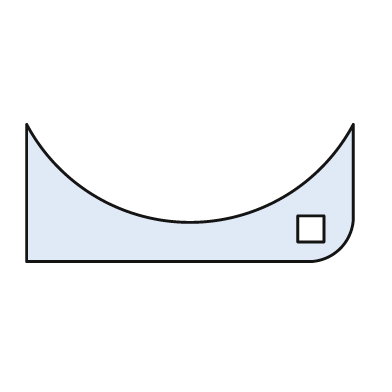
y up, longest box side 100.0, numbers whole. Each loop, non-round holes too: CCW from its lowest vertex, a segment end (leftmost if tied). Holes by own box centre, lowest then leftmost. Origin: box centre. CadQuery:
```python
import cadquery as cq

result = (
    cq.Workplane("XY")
    .moveTo(-50.0, -21.0)
    .lineTo(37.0, -21.0)
    .threePointArc((46.0, -17.0), (50.0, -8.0))
    .lineTo(50.0, 21.0)
    .threePointArc((0.0, -9.0), (-50.0, 21.0))
    .close()
    .moveTo(33.0, -15.0)
    .lineTo(41.0, -15.0)
    .lineTo(41.0, -7.0)
    .lineTo(33.0, -7.0)
    .close()
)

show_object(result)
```